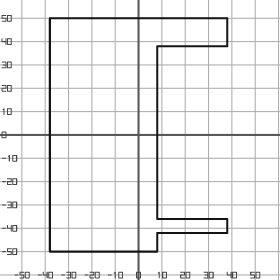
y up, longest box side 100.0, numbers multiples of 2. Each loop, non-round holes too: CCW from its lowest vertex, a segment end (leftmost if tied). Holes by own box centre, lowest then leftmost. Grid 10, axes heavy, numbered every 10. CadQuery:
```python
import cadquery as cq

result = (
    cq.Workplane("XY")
    .moveTo(-38.0, -50.0)
    .lineTo(8.0, -50.0)
    .lineTo(8.0, -42.0)
    .lineTo(38.0, -42.0)
    .lineTo(38.0, -36.0)
    .lineTo(8.0, -36.0)
    .lineTo(8.0, 38.0)
    .lineTo(38.0, 38.0)
    .lineTo(38.0, 50.0)
    .lineTo(-38.0, 50.0)
    .close()
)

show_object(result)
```